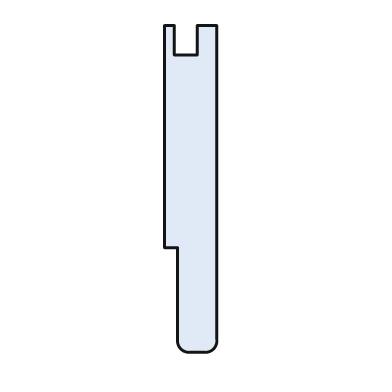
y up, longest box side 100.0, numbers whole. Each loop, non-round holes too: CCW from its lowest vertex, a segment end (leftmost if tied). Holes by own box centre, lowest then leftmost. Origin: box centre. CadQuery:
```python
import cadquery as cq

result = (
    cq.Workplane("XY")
    .moveTo(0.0, -50.0)
    .lineTo(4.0, -50.0)
    .threePointArc((7.0, -49.0), (8.0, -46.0))
    .lineTo(8.0, 50.0)
    .lineTo(2.0, 50.0)
    .lineTo(2.0, 41.0)
    .lineTo(-5.0, 41.0)
    .lineTo(-5.0, 50.0)
    .lineTo(-8.0, 50.0)
    .lineTo(-8.0, -18.0)
    .lineTo(-4.0, -18.0)
    .lineTo(-4.0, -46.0)
    .threePointArc((-3.0, -49.0), (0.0, -50.0))
    .close()
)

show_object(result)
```